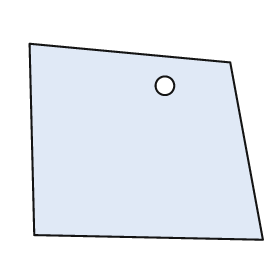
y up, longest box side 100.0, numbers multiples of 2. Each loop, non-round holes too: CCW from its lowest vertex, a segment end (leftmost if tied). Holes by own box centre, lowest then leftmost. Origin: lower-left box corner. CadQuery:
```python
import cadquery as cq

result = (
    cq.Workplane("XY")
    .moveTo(100.0, 0.0)
    .lineTo(86.0, 76.0)
    .lineTo(0.0, 84.0)
    .lineTo(2.0, 2.0)
    .close()
    .moveTo(58.0, 66.0)
    .circle(4.0)
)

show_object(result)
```